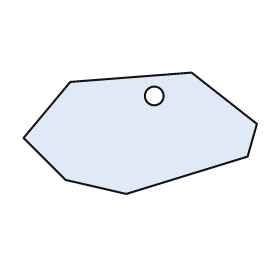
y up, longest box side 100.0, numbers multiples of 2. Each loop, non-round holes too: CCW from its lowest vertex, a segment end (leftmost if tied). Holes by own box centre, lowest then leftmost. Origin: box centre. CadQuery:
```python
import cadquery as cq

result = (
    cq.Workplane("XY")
    .moveTo(-6.0, -26.0)
    .lineTo(46.0, -10.0)
    .lineTo(50.0, 4.0)
    .lineTo(22.0, 26.0)
    .lineTo(-30.0, 22.0)
    .lineTo(-50.0, -2.0)
    .lineTo(-32.0, -20.0)
    .close()
    .moveTo(6.0, 16.0)
    .circle(4.0)
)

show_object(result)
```